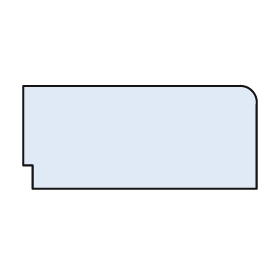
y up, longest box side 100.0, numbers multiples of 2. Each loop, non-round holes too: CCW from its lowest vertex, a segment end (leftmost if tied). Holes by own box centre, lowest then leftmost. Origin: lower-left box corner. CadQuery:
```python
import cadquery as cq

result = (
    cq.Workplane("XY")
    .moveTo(4.0, 0.0)
    .lineTo(100.0, 0.0)
    .lineTo(100.0, 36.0)
    .threePointArc((98.0, 42.0), (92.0, 44.0))
    .lineTo(0.0, 44.0)
    .lineTo(0.0, 10.0)
    .lineTo(4.0, 10.0)
    .close()
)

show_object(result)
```